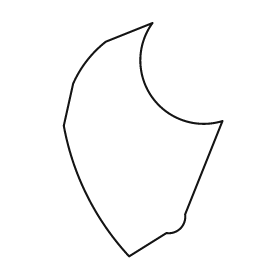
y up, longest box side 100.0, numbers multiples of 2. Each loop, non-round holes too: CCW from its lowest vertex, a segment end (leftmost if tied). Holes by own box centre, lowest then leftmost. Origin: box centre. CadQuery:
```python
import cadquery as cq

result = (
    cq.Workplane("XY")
    .moveTo(-6.0, -50.0)
    .lineTo(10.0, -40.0)
    .threePointArc((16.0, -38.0), (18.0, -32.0))
    .lineTo(34.0, 8.0)
    .threePointArc((4.0, 18.0), (4.0, 50.0))
    .lineTo(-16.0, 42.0)
    .threePointArc((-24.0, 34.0), (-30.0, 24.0))
    .lineTo(-34.0, 6.0)
    .threePointArc((-24.0, -24.0), (-6.0, -50.0))
    .close()
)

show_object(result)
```